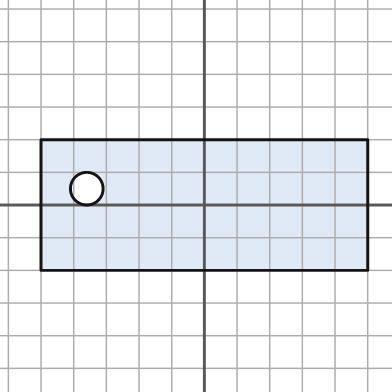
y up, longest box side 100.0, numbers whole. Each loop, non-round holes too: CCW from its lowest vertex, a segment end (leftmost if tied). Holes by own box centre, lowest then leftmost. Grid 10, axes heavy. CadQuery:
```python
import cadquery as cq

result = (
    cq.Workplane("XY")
    .moveTo(-50.0, -20.0)
    .lineTo(50.0, -20.0)
    .lineTo(50.0, 20.0)
    .lineTo(-50.0, 20.0)
    .close()
    .moveTo(-36.0, 5.0)
    .circle(5.0)
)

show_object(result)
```